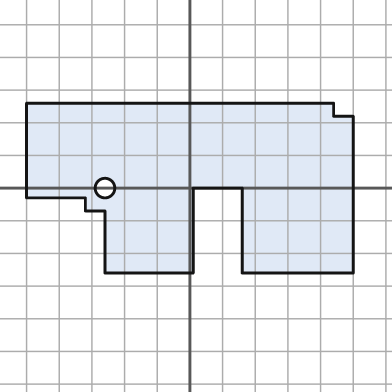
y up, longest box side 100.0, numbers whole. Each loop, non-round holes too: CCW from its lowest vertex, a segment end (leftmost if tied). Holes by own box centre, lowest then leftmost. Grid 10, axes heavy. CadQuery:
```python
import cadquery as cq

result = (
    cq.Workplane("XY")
    .moveTo(-26.0, -26.0)
    .lineTo(1.0, -26.0)
    .lineTo(1.0, 0.0)
    .lineTo(16.0, 0.0)
    .lineTo(16.0, -26.0)
    .lineTo(50.0, -26.0)
    .lineTo(50.0, 22.0)
    .lineTo(44.0, 22.0)
    .lineTo(44.0, 26.0)
    .lineTo(-50.0, 26.0)
    .lineTo(-50.0, -3.0)
    .lineTo(-32.0, -3.0)
    .lineTo(-32.0, -7.0)
    .lineTo(-26.0, -7.0)
    .close()
    .moveTo(-26.0, 0.0)
    .circle(3.0)
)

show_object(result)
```